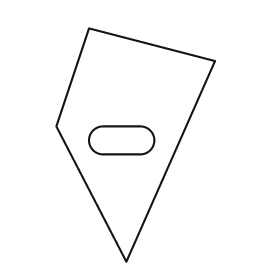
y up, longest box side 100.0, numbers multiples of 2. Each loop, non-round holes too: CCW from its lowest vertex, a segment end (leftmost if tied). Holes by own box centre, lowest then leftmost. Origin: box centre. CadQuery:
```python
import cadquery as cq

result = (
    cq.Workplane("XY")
    .moveTo(-4.0, -50.0)
    .lineTo(34.0, 36.0)
    .lineTo(-20.0, 50.0)
    .lineTo(-34.0, 8.0)
    .close()
    .moveTo(-14.0, -4.0)
    .lineTo(2.0, -4.0)
    .threePointArc((8.0, 2.0), (2.0, 8.0))
    .lineTo(-14.0, 8.0)
    .threePointArc((-20.0, 2.0), (-14.0, -4.0))
    .close()
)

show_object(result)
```